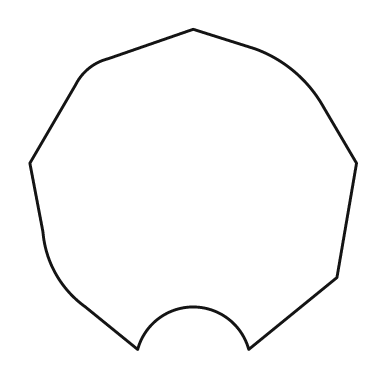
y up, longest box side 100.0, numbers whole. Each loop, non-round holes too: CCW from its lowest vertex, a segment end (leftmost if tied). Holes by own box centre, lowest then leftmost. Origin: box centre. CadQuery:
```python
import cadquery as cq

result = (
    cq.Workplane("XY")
    .moveTo(-17.0, -49.0)
    .threePointArc((0.0, -36.0), (17.0, -49.0))
    .lineTo(44.0, -27.0)
    .lineTo(50.0, 8.0)
    .lineTo(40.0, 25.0)
    .threePointArc((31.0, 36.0), (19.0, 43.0))
    .lineTo(0.0, 49.0)
    .lineTo(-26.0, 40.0)
    .threePointArc((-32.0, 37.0), (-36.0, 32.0))
    .lineTo(-50.0, 8.0)
    .lineTo(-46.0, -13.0)
    .threePointArc((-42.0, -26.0), (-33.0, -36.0))
    .close()
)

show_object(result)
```